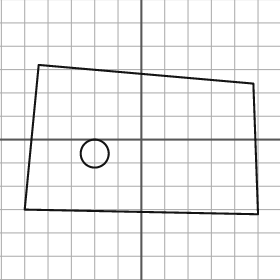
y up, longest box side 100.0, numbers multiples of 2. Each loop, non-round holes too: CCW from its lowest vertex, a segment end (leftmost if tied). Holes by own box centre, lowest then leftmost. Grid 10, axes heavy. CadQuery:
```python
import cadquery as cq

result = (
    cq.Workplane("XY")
    .moveTo(50.0, -32.0)
    .lineTo(48.0, 24.0)
    .lineTo(-44.0, 32.0)
    .lineTo(-50.0, -30.0)
    .close()
    .moveTo(-20.0, -6.0)
    .circle(6.0)
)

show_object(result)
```